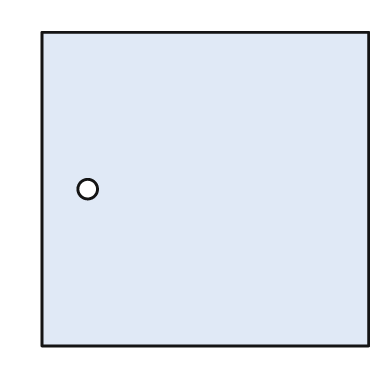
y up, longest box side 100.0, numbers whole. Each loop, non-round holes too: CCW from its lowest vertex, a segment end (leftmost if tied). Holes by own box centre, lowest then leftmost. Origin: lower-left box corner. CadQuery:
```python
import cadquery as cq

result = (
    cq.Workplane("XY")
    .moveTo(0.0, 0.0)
    .lineTo(100.0, 0.0)
    .lineTo(100.0, 96.0)
    .lineTo(0.0, 96.0)
    .close()
    .moveTo(14.0, 48.0)
    .circle(3.0)
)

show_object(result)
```